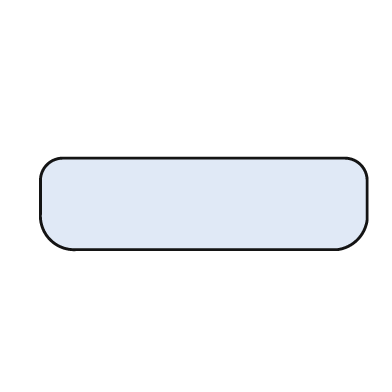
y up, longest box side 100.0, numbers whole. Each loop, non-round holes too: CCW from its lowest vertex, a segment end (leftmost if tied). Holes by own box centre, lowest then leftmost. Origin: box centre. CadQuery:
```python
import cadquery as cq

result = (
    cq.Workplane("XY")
    .moveTo(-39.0, -14.0)
    .lineTo(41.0, -14.0)
    .threePointArc((47.0, -11.0), (50.0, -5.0))
    .lineTo(50.0, 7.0)
    .threePointArc((48.0, 12.0), (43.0, 14.0))
    .lineTo(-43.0, 14.0)
    .threePointArc((-48.0, 12.0), (-50.0, 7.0))
    .lineTo(-50.0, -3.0)
    .threePointArc((-47.0, -11.0), (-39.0, -14.0))
    .close()
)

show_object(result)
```